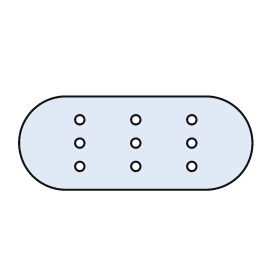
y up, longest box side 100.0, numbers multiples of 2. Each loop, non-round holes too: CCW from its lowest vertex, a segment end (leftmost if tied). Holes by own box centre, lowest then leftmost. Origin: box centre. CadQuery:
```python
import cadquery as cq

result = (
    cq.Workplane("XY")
    .moveTo(-30.0, -20.0)
    .lineTo(30.0, -20.0)
    .threePointArc((50.0, 0.0), (30.0, 20.0))
    .lineTo(-30.0, 20.0)
    .threePointArc((-50.0, 0.0), (-30.0, -20.0))
    .close()
    .moveTo(-24.0, -10.0)
    .circle(2.0)
    .moveTo(0.0, -10.0)
    .circle(2.0)
    .moveTo(24.0, -10.0)
    .circle(2.0)
    .moveTo(-24.0, 0.0)
    .circle(2.0)
    .moveTo(0.0, 0.0)
    .circle(2.0)
    .moveTo(24.0, 0.0)
    .circle(2.0)
    .moveTo(-24.0, 10.0)
    .circle(2.0)
    .moveTo(0.0, 10.0)
    .circle(2.0)
    .moveTo(24.0, 10.0)
    .circle(2.0)
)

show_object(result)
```